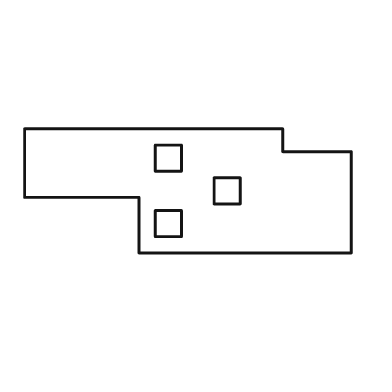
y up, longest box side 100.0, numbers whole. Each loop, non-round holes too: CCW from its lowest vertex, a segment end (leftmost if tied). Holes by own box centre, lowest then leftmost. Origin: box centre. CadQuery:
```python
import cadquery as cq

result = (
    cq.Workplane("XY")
    .moveTo(-15.0, -19.0)
    .lineTo(50.0, -19.0)
    .lineTo(50.0, 12.0)
    .lineTo(29.0, 12.0)
    .lineTo(29.0, 19.0)
    .lineTo(-50.0, 19.0)
    .lineTo(-50.0, -2.0)
    .lineTo(-15.0, -2.0)
    .close()
    .moveTo(-10.0, -14.0)
    .lineTo(-2.0, -14.0)
    .lineTo(-2.0, -6.0)
    .lineTo(-10.0, -6.0)
    .close()
    .moveTo(8.0, -4.0)
    .lineTo(16.0, -4.0)
    .lineTo(16.0, 4.0)
    .lineTo(8.0, 4.0)
    .close()
    .moveTo(-10.0, 6.0)
    .lineTo(-2.0, 6.0)
    .lineTo(-2.0, 14.0)
    .lineTo(-10.0, 14.0)
    .close()
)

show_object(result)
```